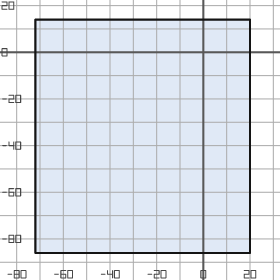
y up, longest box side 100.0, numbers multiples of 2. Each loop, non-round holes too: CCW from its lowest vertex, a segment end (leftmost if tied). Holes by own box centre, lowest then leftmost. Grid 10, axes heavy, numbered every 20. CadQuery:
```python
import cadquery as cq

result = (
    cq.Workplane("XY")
    .moveTo(-72.0, -86.0)
    .lineTo(20.0, -86.0)
    .lineTo(20.0, 14.0)
    .lineTo(-72.0, 14.0)
    .close()
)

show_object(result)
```